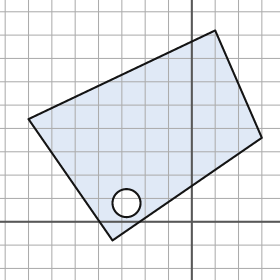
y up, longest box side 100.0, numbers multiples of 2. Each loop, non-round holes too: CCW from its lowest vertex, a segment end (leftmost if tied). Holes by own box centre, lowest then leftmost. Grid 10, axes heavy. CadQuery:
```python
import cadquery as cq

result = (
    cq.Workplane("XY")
    .moveTo(-34.0, -8.0)
    .lineTo(30.0, 36.0)
    .lineTo(10.0, 82.0)
    .lineTo(-70.0, 44.0)
    .close()
    .moveTo(-28.0, 8.0)
    .circle(6.0)
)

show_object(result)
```